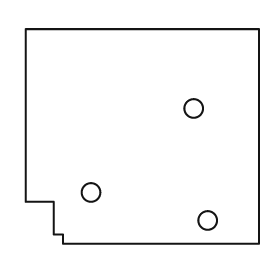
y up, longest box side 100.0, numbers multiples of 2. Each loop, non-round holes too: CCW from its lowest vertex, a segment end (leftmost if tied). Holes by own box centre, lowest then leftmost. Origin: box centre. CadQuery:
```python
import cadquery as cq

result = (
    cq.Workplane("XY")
    .moveTo(-34.0, -46.0)
    .lineTo(50.0, -46.0)
    .lineTo(50.0, 46.0)
    .lineTo(-50.0, 46.0)
    .lineTo(-50.0, -28.0)
    .lineTo(-38.0, -28.0)
    .lineTo(-38.0, -42.0)
    .lineTo(-34.0, -42.0)
    .close()
    .moveTo(28.0, -36.0)
    .circle(4.0)
    .moveTo(-22.0, -24.0)
    .circle(4.0)
    .moveTo(22.0, 12.0)
    .circle(4.0)
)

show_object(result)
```